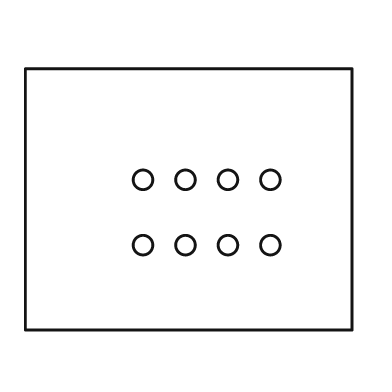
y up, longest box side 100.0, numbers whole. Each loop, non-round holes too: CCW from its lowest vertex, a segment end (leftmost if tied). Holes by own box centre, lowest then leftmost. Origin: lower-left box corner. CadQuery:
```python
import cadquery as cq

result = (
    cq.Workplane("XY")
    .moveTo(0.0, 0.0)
    .lineTo(100.0, 0.0)
    .lineTo(100.0, 80.0)
    .lineTo(0.0, 80.0)
    .close()
    .moveTo(36.0, 26.0)
    .circle(3.0)
    .moveTo(49.0, 26.0)
    .circle(3.0)
    .moveTo(62.0, 26.0)
    .circle(3.0)
    .moveTo(75.0, 26.0)
    .circle(3.0)
    .moveTo(36.0, 46.0)
    .circle(3.0)
    .moveTo(49.0, 46.0)
    .circle(3.0)
    .moveTo(62.0, 46.0)
    .circle(3.0)
    .moveTo(75.0, 46.0)
    .circle(3.0)
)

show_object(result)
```